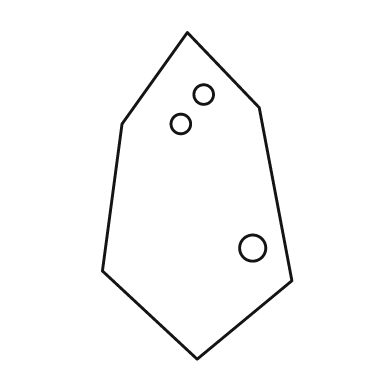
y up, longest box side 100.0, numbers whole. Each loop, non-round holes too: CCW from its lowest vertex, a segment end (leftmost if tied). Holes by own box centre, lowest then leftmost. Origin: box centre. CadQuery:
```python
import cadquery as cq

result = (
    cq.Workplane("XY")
    .moveTo(0.0, -50.0)
    .lineTo(29.0, -26.0)
    .lineTo(19.0, 27.0)
    .lineTo(-3.0, 50.0)
    .lineTo(-23.0, 22.0)
    .lineTo(-29.0, -23.0)
    .close()
    .moveTo(17.0, -16.0)
    .circle(4.0)
    .moveTo(-5.0, 22.0)
    .circle(3.0)
    .moveTo(2.0, 31.0)
    .circle(3.0)
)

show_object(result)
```